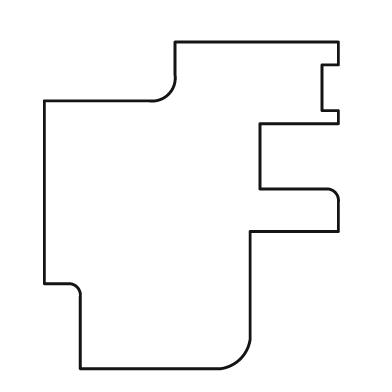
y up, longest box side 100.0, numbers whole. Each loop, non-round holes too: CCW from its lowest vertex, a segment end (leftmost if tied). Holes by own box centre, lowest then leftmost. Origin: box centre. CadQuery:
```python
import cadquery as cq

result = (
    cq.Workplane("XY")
    .moveTo(-34.0, -50.0)
    .lineTo(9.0, -50.0)
    .threePointArc((15.0, -47.0), (18.0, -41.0))
    .lineTo(18.0, -8.0)
    .lineTo(45.0, -8.0)
    .lineTo(45.0, 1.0)
    .threePointArc((44.0, 4.0), (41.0, 5.0))
    .lineTo(21.0, 5.0)
    .lineTo(21.0, 25.0)
    .lineTo(45.0, 25.0)
    .lineTo(45.0, 29.0)
    .lineTo(40.0, 29.0)
    .lineTo(40.0, 43.0)
    .lineTo(45.0, 43.0)
    .lineTo(45.0, 50.0)
    .lineTo(-5.0, 50.0)
    .lineTo(-5.0, 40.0)
    .threePointArc((-7.0, 34.0), (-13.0, 32.0))
    .lineTo(-45.0, 32.0)
    .lineTo(-45.0, -24.0)
    .lineTo(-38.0, -24.0)
    .threePointArc((-35.0, -25.0), (-34.0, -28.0))
    .close()
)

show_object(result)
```